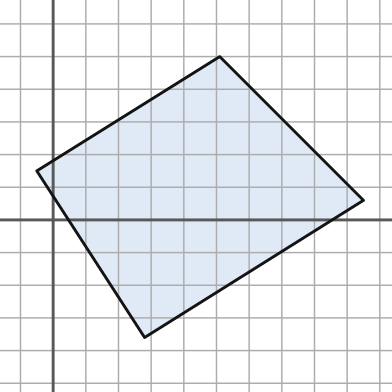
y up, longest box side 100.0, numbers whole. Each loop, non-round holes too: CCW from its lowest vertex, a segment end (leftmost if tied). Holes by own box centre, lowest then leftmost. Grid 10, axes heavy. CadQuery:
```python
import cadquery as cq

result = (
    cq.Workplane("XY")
    .moveTo(28.0, -36.0)
    .lineTo(95.0, 6.0)
    .lineTo(51.0, 50.0)
    .lineTo(-5.0, 15.0)
    .close()
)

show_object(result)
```